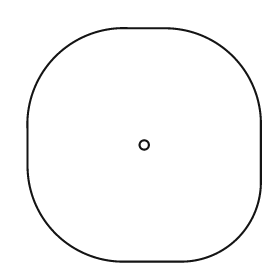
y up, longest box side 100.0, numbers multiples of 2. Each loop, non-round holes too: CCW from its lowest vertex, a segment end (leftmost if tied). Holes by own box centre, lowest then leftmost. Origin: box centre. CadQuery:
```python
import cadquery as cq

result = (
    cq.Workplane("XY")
    .moveTo(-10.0, -50.0)
    .lineTo(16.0, -50.0)
    .threePointArc((40.0, -40.0), (50.0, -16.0))
    .lineTo(50.0, 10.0)
    .threePointArc((38.0, 38.0), (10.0, 50.0))
    .lineTo(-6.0, 50.0)
    .threePointArc((-38.0, 38.0), (-50.0, 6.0))
    .lineTo(-50.0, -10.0)
    .threePointArc((-38.0, -38.0), (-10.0, -50.0))
    .close()
    .moveTo(0.0, 0.0)
    .circle(2.0)
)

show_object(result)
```